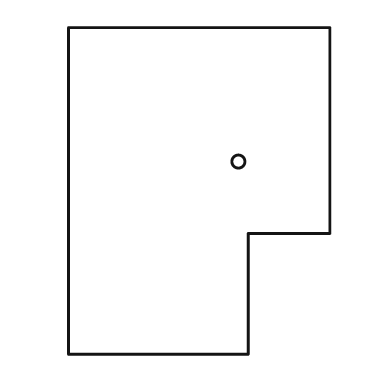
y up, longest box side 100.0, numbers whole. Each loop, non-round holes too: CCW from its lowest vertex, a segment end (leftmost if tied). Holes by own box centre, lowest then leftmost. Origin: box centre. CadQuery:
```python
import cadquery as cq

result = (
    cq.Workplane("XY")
    .moveTo(-40.0, -50.0)
    .lineTo(15.0, -50.0)
    .lineTo(15.0, -13.0)
    .lineTo(40.0, -13.0)
    .lineTo(40.0, 50.0)
    .lineTo(-40.0, 50.0)
    .close()
    .moveTo(12.0, 9.0)
    .circle(2.0)
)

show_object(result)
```